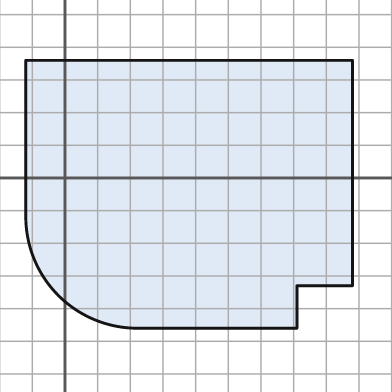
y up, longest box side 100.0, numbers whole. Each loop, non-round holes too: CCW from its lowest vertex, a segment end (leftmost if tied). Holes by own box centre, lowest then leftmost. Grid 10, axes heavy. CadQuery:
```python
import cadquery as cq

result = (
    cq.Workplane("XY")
    .moveTo(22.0, -46.0)
    .lineTo(71.0, -46.0)
    .lineTo(71.0, -33.0)
    .lineTo(88.0, -33.0)
    .lineTo(88.0, 36.0)
    .lineTo(-12.0, 36.0)
    .lineTo(-12.0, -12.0)
    .threePointArc((-2.0, -36.0), (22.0, -46.0))
    .close()
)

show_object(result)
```